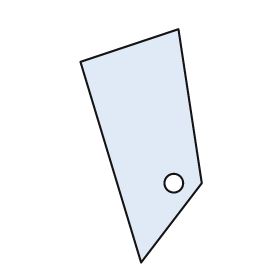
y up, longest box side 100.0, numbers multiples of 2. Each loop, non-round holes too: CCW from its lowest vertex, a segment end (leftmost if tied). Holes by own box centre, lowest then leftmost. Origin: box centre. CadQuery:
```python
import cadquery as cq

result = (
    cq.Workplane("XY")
    .moveTo(0.0, -50.0)
    .lineTo(26.0, -16.0)
    .lineTo(16.0, 50.0)
    .lineTo(-26.0, 36.0)
    .close()
    .moveTo(14.0, -16.0)
    .circle(4.0)
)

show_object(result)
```